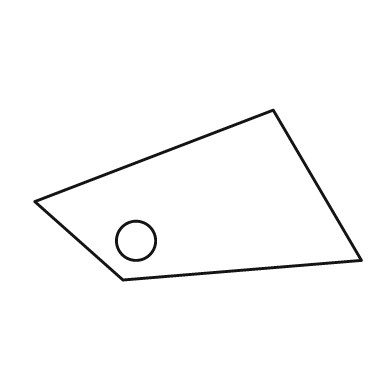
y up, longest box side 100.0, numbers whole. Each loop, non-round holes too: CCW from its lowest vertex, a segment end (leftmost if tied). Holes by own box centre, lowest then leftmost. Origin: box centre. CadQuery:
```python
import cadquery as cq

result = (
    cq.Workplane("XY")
    .moveTo(-23.0, -26.0)
    .lineTo(50.0, -20.0)
    .lineTo(23.0, 26.0)
    .lineTo(-50.0, -2.0)
    .close()
    .moveTo(-19.0, -14.0)
    .circle(6.0)
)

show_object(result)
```